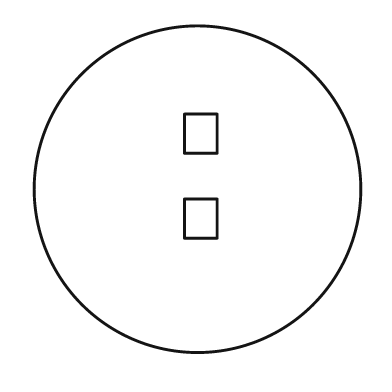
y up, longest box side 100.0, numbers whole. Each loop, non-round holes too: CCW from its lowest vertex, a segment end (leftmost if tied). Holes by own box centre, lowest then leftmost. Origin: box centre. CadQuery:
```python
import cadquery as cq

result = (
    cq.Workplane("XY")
    .moveTo(0.0, 0.0)
    .circle(50.0)
    .moveTo(-4.0, -15.0)
    .lineTo(6.0, -15.0)
    .lineTo(6.0, -3.0)
    .lineTo(-4.0, -3.0)
    .close()
    .moveTo(-4.0, 11.0)
    .lineTo(6.0, 11.0)
    .lineTo(6.0, 23.0)
    .lineTo(-4.0, 23.0)
    .close()
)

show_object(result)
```